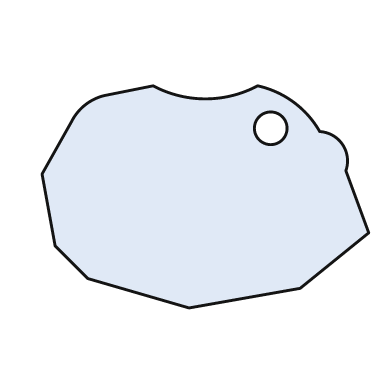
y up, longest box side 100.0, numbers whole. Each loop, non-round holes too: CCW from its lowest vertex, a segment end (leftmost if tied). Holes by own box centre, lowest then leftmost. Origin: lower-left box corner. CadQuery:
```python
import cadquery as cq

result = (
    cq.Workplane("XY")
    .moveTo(45.0, 0.0)
    .lineTo(79.0, 6.0)
    .lineTo(100.0, 23.0)
    .lineTo(93.0, 42.0)
    .threePointArc((92.0, 50.0), (85.0, 54.0))
    .threePointArc((77.0, 63.0), (66.0, 68.0))
    .threePointArc((50.0, 64.0), (34.0, 68.0))
    .lineTo(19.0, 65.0)
    .threePointArc((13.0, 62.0), (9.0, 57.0))
    .lineTo(0.0, 41.0)
    .lineTo(4.0, 19.0)
    .lineTo(14.0, 9.0)
    .close()
    .moveTo(70.0, 55.0)
    .circle(5.0)
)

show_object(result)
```